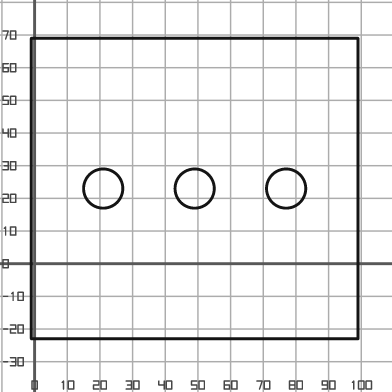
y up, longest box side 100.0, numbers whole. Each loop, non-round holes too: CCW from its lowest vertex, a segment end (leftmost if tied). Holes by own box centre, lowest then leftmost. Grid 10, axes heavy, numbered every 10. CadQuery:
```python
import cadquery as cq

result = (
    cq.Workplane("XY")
    .moveTo(-1.0, -23.0)
    .lineTo(99.0, -23.0)
    .lineTo(99.0, 69.0)
    .lineTo(-1.0, 69.0)
    .close()
    .moveTo(21.0, 23.0)
    .circle(6.0)
    .moveTo(49.0, 23.0)
    .circle(6.0)
    .moveTo(77.0, 23.0)
    .circle(6.0)
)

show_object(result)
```